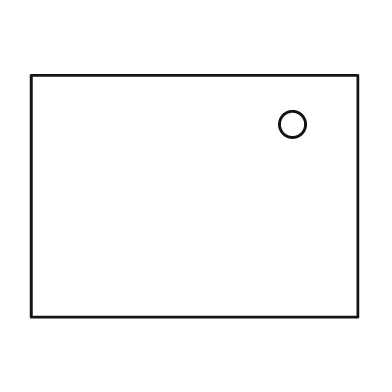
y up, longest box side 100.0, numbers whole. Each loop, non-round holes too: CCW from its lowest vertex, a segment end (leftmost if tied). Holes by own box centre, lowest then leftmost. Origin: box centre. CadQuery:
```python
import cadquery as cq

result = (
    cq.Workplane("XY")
    .moveTo(-50.0, -37.0)
    .lineTo(50.0, -37.0)
    .lineTo(50.0, 37.0)
    .lineTo(-50.0, 37.0)
    .close()
    .moveTo(30.0, 22.0)
    .circle(4.0)
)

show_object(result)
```